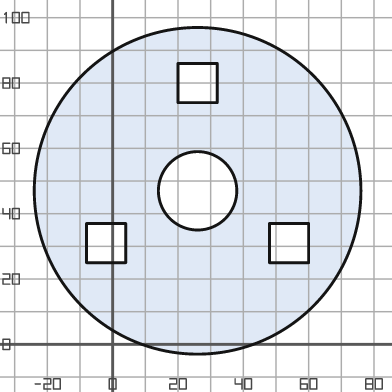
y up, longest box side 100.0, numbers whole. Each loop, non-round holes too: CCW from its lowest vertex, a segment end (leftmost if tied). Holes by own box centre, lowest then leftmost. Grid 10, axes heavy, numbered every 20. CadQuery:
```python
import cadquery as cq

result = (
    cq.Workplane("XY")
    .moveTo(26.0, 47.0)
    .circle(50.0)
    .moveTo(-8.0, 25.0)
    .lineTo(4.0, 25.0)
    .lineTo(4.0, 37.0)
    .lineTo(-8.0, 37.0)
    .close()
    .moveTo(48.0, 25.0)
    .lineTo(60.0, 25.0)
    .lineTo(60.0, 37.0)
    .lineTo(48.0, 37.0)
    .close()
    .moveTo(26.0, 47.0)
    .circle(12.0)
    .moveTo(20.0, 74.0)
    .lineTo(32.0, 74.0)
    .lineTo(32.0, 86.0)
    .lineTo(20.0, 86.0)
    .close()
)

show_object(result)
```